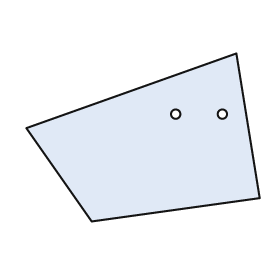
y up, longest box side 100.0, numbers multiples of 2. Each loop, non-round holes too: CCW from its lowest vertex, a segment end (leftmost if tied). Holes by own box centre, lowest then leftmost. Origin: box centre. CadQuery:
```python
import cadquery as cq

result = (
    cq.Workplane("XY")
    .moveTo(-22.0, -36.0)
    .lineTo(50.0, -26.0)
    .lineTo(40.0, 36.0)
    .lineTo(-50.0, 4.0)
    .close()
    .moveTo(14.0, 10.0)
    .circle(2.0)
    .moveTo(34.0, 10.0)
    .circle(2.0)
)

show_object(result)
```